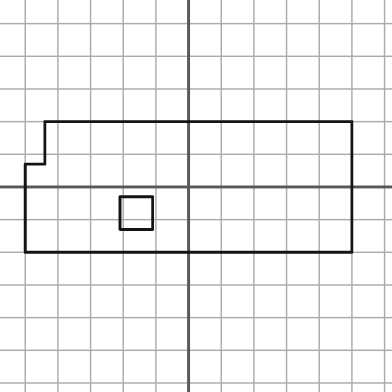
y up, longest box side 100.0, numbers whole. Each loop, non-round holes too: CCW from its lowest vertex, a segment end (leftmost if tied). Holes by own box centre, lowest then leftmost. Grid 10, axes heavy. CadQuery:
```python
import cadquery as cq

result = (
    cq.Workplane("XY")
    .moveTo(-50.0, -20.0)
    .lineTo(50.0, -20.0)
    .lineTo(50.0, 20.0)
    .lineTo(-44.0, 20.0)
    .lineTo(-44.0, 7.0)
    .lineTo(-50.0, 7.0)
    .close()
    .moveTo(-21.0, -13.0)
    .lineTo(-11.0, -13.0)
    .lineTo(-11.0, -3.0)
    .lineTo(-21.0, -3.0)
    .close()
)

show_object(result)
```